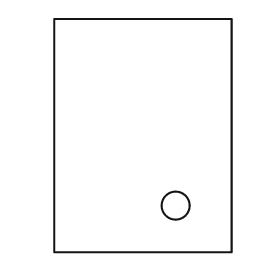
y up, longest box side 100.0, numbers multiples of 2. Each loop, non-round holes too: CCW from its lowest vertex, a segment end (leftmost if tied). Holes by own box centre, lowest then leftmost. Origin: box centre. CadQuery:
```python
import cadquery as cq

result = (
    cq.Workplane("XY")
    .moveTo(-38.0, -50.0)
    .lineTo(38.0, -50.0)
    .lineTo(38.0, 50.0)
    .lineTo(-38.0, 50.0)
    .close()
    .moveTo(14.0, -30.0)
    .circle(6.0)
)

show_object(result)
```